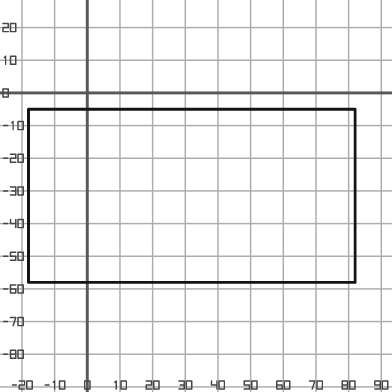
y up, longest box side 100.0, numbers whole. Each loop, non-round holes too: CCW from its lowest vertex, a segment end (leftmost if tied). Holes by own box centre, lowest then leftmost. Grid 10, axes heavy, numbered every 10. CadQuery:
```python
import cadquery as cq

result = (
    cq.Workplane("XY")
    .moveTo(-18.0, -58.0)
    .lineTo(82.0, -58.0)
    .lineTo(82.0, -5.0)
    .lineTo(-18.0, -5.0)
    .close()
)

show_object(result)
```